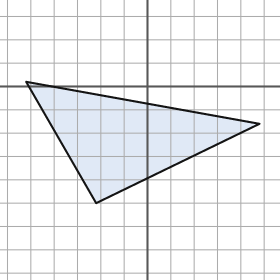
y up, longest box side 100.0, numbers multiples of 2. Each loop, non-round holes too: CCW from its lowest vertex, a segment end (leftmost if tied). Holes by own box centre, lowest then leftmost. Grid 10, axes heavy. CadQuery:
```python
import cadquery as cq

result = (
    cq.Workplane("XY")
    .moveTo(-22.0, -50.0)
    .lineTo(48.0, -16.0)
    .lineTo(-52.0, 2.0)
    .close()
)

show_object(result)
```